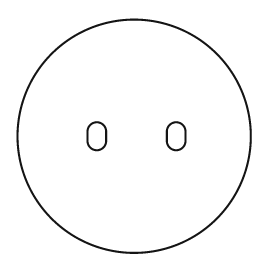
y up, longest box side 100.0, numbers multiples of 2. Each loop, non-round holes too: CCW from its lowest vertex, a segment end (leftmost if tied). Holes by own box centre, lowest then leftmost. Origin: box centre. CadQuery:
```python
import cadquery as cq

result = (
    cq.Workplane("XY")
    .moveTo(0.0, 0.0)
    .circle(50.0)
    .moveTo(-20.0, -2.0)
    .threePointArc((-16.0, -6.0), (-12.0, -2.0))
    .lineTo(-12.0, 2.0)
    .threePointArc((-16.0, 6.0), (-20.0, 2.0))
    .close()
    .moveTo(14.0, -2.0)
    .threePointArc((18.0, -6.0), (22.0, -2.0))
    .lineTo(22.0, 2.0)
    .threePointArc((18.0, 6.0), (14.0, 2.0))
    .close()
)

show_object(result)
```